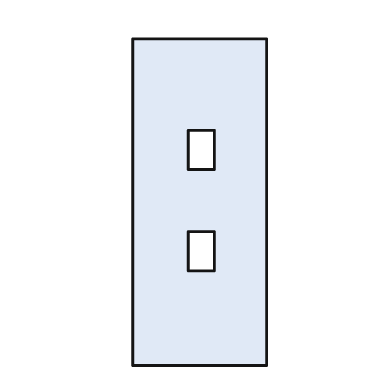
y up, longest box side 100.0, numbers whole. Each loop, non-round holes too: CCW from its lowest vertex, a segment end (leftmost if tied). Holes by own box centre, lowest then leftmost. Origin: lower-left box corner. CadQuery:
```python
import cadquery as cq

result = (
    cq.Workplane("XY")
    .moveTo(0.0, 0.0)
    .lineTo(41.0, 0.0)
    .lineTo(41.0, 100.0)
    .lineTo(0.0, 100.0)
    .close()
    .moveTo(17.0, 29.0)
    .lineTo(25.0, 29.0)
    .lineTo(25.0, 41.0)
    .lineTo(17.0, 41.0)
    .close()
    .moveTo(17.0, 60.0)
    .lineTo(25.0, 60.0)
    .lineTo(25.0, 72.0)
    .lineTo(17.0, 72.0)
    .close()
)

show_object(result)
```